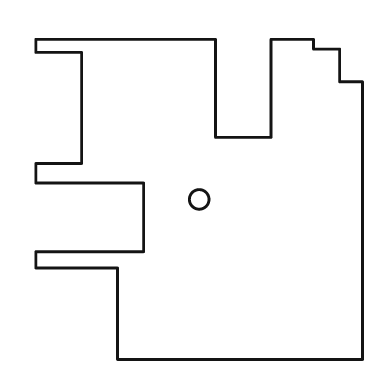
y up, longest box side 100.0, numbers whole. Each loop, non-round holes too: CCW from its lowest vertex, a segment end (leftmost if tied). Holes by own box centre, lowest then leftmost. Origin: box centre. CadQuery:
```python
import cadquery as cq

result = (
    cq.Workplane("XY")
    .moveTo(-25.0, -49.0)
    .lineTo(50.0, -49.0)
    .lineTo(50.0, 36.0)
    .lineTo(43.0, 36.0)
    .lineTo(43.0, 46.0)
    .lineTo(35.0, 46.0)
    .lineTo(35.0, 49.0)
    .lineTo(22.0, 49.0)
    .lineTo(22.0, 19.0)
    .lineTo(5.0, 19.0)
    .lineTo(5.0, 49.0)
    .lineTo(-50.0, 49.0)
    .lineTo(-50.0, 45.0)
    .lineTo(-36.0, 45.0)
    .lineTo(-36.0, 11.0)
    .lineTo(-50.0, 11.0)
    .lineTo(-50.0, 5.0)
    .lineTo(-17.0, 5.0)
    .lineTo(-17.0, -16.0)
    .lineTo(-50.0, -16.0)
    .lineTo(-50.0, -21.0)
    .lineTo(-25.0, -21.0)
    .close()
    .moveTo(0.0, 0.0)
    .circle(3.0)
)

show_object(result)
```